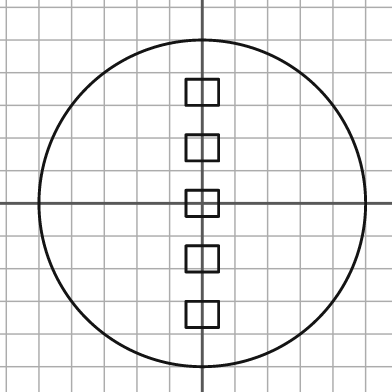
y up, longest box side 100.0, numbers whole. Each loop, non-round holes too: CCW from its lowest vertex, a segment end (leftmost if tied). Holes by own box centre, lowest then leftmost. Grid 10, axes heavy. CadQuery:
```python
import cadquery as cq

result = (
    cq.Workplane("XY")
    .moveTo(0.0, 0.0)
    .circle(50.0)
    .moveTo(-5.0, -38.0)
    .lineTo(5.0, -38.0)
    .lineTo(5.0, -30.0)
    .lineTo(-5.0, -30.0)
    .close()
    .moveTo(-5.0, -21.0)
    .lineTo(5.0, -21.0)
    .lineTo(5.0, -13.0)
    .lineTo(-5.0, -13.0)
    .close()
    .moveTo(-5.0, -4.0)
    .lineTo(5.0, -4.0)
    .lineTo(5.0, 4.0)
    .lineTo(-5.0, 4.0)
    .close()
    .moveTo(-5.0, 13.0)
    .lineTo(5.0, 13.0)
    .lineTo(5.0, 21.0)
    .lineTo(-5.0, 21.0)
    .close()
    .moveTo(-5.0, 30.0)
    .lineTo(5.0, 30.0)
    .lineTo(5.0, 38.0)
    .lineTo(-5.0, 38.0)
    .close()
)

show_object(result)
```